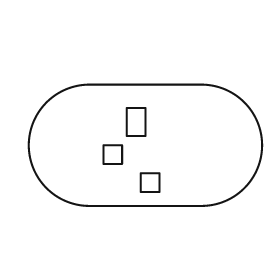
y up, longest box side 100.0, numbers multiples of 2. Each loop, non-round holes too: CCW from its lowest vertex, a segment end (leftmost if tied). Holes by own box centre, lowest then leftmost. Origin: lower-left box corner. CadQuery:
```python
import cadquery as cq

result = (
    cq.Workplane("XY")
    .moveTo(26.0, 0.0)
    .lineTo(74.0, 0.0)
    .threePointArc((100.0, 26.0), (74.0, 52.0))
    .lineTo(26.0, 52.0)
    .threePointArc((0.0, 26.0), (26.0, 0.0))
    .close()
    .moveTo(48.0, 6.0)
    .lineTo(56.0, 6.0)
    .lineTo(56.0, 14.0)
    .lineTo(48.0, 14.0)
    .close()
    .moveTo(32.0, 18.0)
    .lineTo(40.0, 18.0)
    .lineTo(40.0, 26.0)
    .lineTo(32.0, 26.0)
    .close()
    .moveTo(42.0, 30.0)
    .lineTo(50.0, 30.0)
    .lineTo(50.0, 42.0)
    .lineTo(42.0, 42.0)
    .close()
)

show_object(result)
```